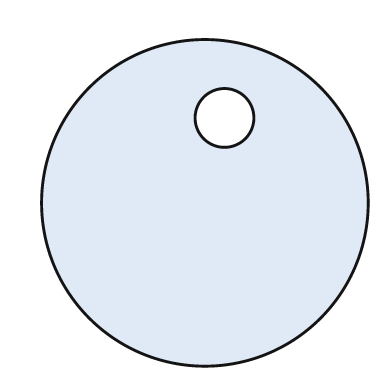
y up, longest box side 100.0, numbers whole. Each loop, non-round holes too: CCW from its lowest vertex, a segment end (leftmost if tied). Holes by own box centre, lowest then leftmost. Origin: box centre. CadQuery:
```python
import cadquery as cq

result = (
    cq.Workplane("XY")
    .moveTo(0.0, 0.0)
    .circle(50.0)
    .moveTo(6.0, 26.0)
    .circle(9.0)
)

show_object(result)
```